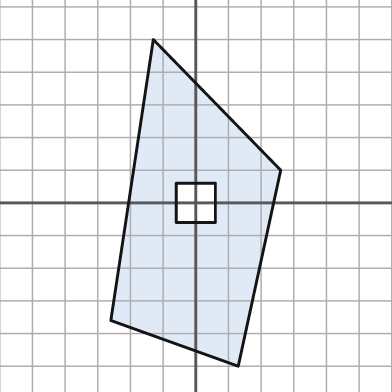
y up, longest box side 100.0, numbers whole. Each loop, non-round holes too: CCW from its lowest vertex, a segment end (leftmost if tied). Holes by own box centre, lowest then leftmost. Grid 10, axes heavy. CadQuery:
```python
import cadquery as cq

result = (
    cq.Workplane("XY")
    .moveTo(13.0, -50.0)
    .lineTo(26.0, 10.0)
    .lineTo(-13.0, 50.0)
    .lineTo(-26.0, -36.0)
    .close()
    .moveTo(-6.0, -6.0)
    .lineTo(6.0, -6.0)
    .lineTo(6.0, 6.0)
    .lineTo(-6.0, 6.0)
    .close()
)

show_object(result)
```